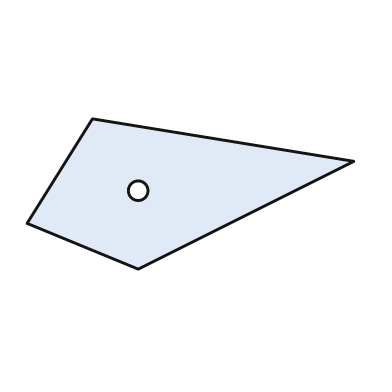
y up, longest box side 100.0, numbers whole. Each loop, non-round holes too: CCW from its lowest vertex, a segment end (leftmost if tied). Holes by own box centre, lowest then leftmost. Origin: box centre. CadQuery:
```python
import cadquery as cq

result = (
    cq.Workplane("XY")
    .moveTo(-16.0, -23.0)
    .lineTo(50.0, 10.0)
    .lineTo(-30.0, 23.0)
    .lineTo(-50.0, -9.0)
    .close()
    .moveTo(-16.0, 1.0)
    .circle(3.0)
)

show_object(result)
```